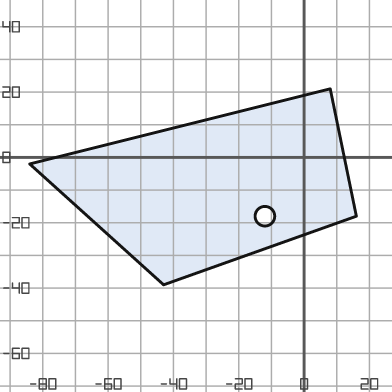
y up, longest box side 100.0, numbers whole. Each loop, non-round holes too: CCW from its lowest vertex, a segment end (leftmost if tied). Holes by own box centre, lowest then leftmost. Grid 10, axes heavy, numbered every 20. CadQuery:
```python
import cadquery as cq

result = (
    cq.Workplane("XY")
    .moveTo(-43.0, -39.0)
    .lineTo(16.0, -18.0)
    .lineTo(8.0, 21.0)
    .lineTo(-84.0, -2.0)
    .close()
    .moveTo(-12.0, -18.0)
    .circle(3.0)
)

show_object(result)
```